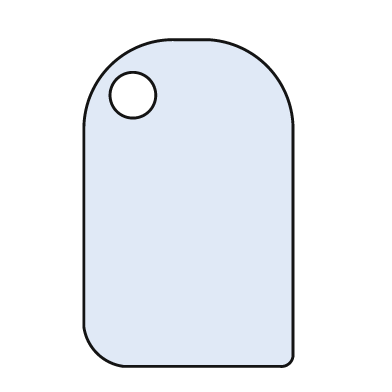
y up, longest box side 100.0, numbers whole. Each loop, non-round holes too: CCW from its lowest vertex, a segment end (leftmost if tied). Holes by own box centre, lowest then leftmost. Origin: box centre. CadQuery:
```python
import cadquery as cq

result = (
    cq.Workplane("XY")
    .moveTo(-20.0, -50.0)
    .lineTo(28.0, -50.0)
    .threePointArc((31.0, -49.0), (32.0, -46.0))
    .lineTo(32.0, 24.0)
    .threePointArc((24.0, 42.0), (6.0, 50.0))
    .lineTo(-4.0, 50.0)
    .threePointArc((-24.0, 42.0), (-32.0, 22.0))
    .lineTo(-32.0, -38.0)
    .threePointArc((-28.0, -46.0), (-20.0, -50.0))
    .close()
    .moveTo(-17.0, 33.0)
    .circle(7.0)
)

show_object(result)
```